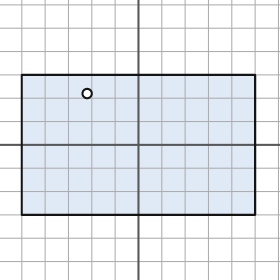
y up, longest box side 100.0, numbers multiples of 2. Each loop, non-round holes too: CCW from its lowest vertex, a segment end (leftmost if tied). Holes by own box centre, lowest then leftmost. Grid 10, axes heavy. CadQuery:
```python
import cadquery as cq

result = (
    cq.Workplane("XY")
    .moveTo(-50.0, -30.0)
    .lineTo(50.0, -30.0)
    .lineTo(50.0, 30.0)
    .lineTo(-50.0, 30.0)
    .close()
    .moveTo(-22.0, 22.0)
    .circle(2.0)
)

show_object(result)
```